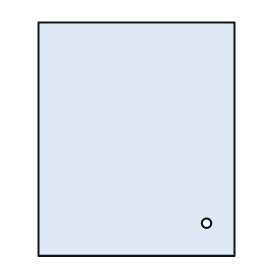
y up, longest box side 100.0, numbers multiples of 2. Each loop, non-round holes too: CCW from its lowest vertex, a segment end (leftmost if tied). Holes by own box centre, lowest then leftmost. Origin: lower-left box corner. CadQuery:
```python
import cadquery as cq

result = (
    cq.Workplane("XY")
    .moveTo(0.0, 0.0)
    .lineTo(84.0, 0.0)
    .lineTo(84.0, 100.0)
    .lineTo(0.0, 100.0)
    .close()
    .moveTo(72.0, 14.0)
    .circle(2.0)
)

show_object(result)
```